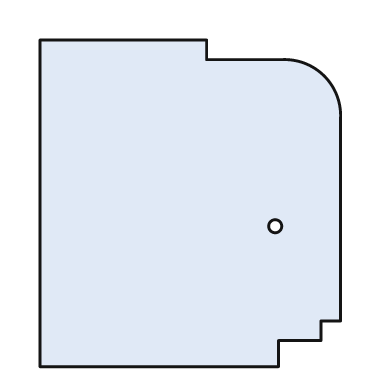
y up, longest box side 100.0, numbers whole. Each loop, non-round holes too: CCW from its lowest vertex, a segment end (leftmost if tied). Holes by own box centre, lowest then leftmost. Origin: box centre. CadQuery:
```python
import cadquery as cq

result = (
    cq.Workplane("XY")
    .moveTo(-46.0, -50.0)
    .lineTo(27.0, -50.0)
    .lineTo(27.0, -42.0)
    .lineTo(40.0, -42.0)
    .lineTo(40.0, -36.0)
    .lineTo(46.0, -36.0)
    .lineTo(46.0, 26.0)
    .threePointArc((41.0, 39.0), (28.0, 44.0))
    .lineTo(5.0, 44.0)
    .lineTo(5.0, 50.0)
    .lineTo(-46.0, 50.0)
    .close()
    .moveTo(26.0, -7.0)
    .circle(2.0)
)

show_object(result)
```